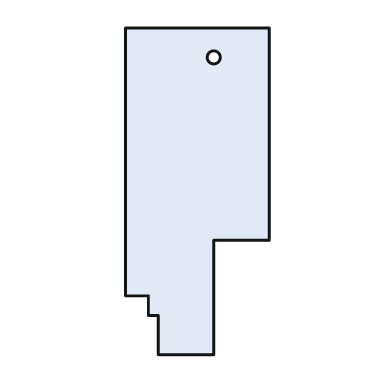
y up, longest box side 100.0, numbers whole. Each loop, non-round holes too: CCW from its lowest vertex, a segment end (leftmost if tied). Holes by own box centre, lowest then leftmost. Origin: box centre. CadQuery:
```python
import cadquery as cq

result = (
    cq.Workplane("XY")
    .moveTo(-12.0, -50.0)
    .lineTo(5.0, -50.0)
    .lineTo(5.0, -15.0)
    .lineTo(22.0, -15.0)
    .lineTo(22.0, 50.0)
    .lineTo(-22.0, 50.0)
    .lineTo(-22.0, -32.0)
    .lineTo(-15.0, -32.0)
    .lineTo(-15.0, -38.0)
    .lineTo(-12.0, -38.0)
    .close()
    .moveTo(5.0, 41.0)
    .circle(2.0)
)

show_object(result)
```